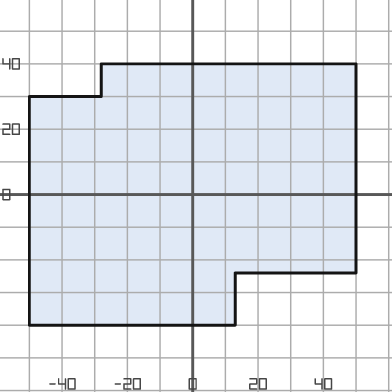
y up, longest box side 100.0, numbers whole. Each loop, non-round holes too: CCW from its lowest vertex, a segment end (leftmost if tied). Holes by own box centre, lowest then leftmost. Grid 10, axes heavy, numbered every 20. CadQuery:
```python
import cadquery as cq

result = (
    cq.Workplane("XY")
    .moveTo(-50.0, -40.0)
    .lineTo(13.0, -40.0)
    .lineTo(13.0, -24.0)
    .lineTo(50.0, -24.0)
    .lineTo(50.0, 40.0)
    .lineTo(-28.0, 40.0)
    .lineTo(-28.0, 30.0)
    .lineTo(-50.0, 30.0)
    .close()
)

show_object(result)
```